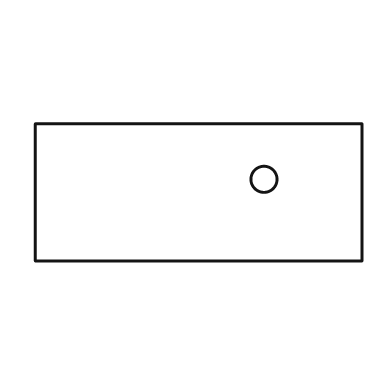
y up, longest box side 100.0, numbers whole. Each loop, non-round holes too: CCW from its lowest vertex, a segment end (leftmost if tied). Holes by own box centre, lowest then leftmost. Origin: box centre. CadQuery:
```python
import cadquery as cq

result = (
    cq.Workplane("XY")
    .moveTo(-50.0, -21.0)
    .lineTo(50.0, -21.0)
    .lineTo(50.0, 21.0)
    .lineTo(-50.0, 21.0)
    .close()
    .moveTo(20.0, 4.0)
    .circle(4.0)
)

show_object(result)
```